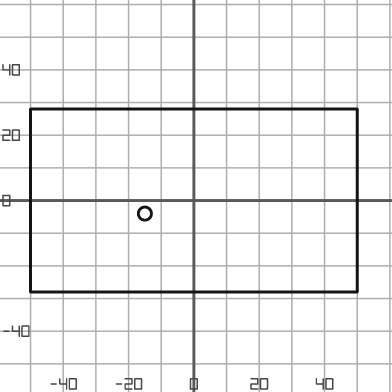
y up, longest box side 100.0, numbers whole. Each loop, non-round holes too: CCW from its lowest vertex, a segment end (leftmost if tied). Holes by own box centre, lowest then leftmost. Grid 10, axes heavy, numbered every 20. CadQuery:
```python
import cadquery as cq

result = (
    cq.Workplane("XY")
    .moveTo(-50.0, -28.0)
    .lineTo(50.0, -28.0)
    .lineTo(50.0, 28.0)
    .lineTo(-50.0, 28.0)
    .close()
    .moveTo(-15.0, -4.0)
    .circle(2.0)
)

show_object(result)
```